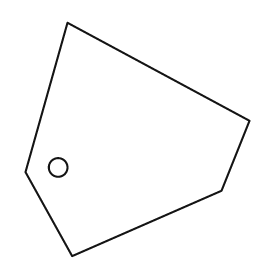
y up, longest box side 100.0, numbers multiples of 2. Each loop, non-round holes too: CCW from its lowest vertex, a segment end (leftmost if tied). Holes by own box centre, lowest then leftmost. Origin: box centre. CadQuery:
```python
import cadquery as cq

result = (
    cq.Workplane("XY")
    .moveTo(-28.0, -50.0)
    .lineTo(36.0, -22.0)
    .lineTo(48.0, 8.0)
    .lineTo(-30.0, 50.0)
    .lineTo(-48.0, -14.0)
    .close()
    .moveTo(-34.0, -12.0)
    .circle(4.0)
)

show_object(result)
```